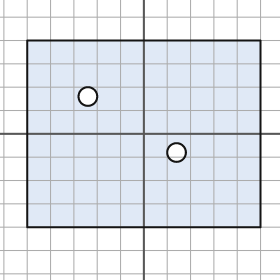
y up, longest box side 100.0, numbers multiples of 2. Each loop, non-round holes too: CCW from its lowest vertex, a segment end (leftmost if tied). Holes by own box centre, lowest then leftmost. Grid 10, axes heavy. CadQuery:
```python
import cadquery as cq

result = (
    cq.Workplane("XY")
    .moveTo(-50.0, -40.0)
    .lineTo(50.0, -40.0)
    .lineTo(50.0, 40.0)
    .lineTo(-50.0, 40.0)
    .close()
    .moveTo(14.0, -8.0)
    .circle(4.0)
    .moveTo(-24.0, 16.0)
    .circle(4.0)
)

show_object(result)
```